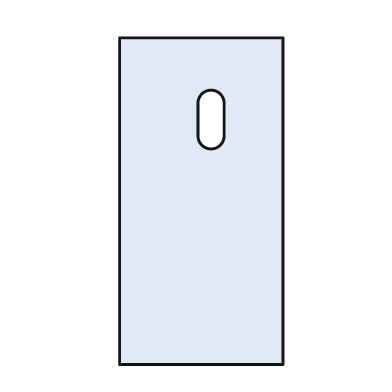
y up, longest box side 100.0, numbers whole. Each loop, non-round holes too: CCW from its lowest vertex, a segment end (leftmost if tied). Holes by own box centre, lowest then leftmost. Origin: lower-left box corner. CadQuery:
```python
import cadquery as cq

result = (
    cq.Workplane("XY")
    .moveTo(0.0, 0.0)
    .lineTo(50.0, 0.0)
    .lineTo(50.0, 100.0)
    .lineTo(0.0, 100.0)
    .close()
    .moveTo(24.0, 70.0)
    .threePointArc((28.0, 66.0), (32.0, 70.0))
    .lineTo(32.0, 80.0)
    .threePointArc((28.0, 84.0), (24.0, 80.0))
    .close()
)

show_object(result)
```